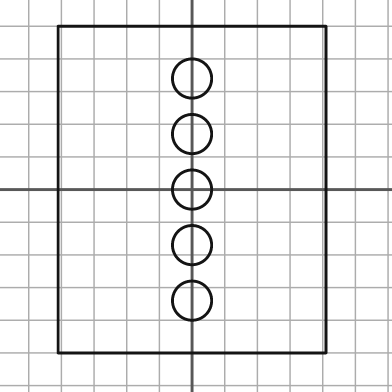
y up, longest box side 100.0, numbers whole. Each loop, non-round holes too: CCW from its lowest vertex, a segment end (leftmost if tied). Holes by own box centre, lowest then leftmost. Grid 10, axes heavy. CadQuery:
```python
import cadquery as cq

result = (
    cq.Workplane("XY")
    .moveTo(-41.0, -50.0)
    .lineTo(41.0, -50.0)
    .lineTo(41.0, 50.0)
    .lineTo(-41.0, 50.0)
    .close()
    .moveTo(0.0, -34.0)
    .circle(6.0)
    .moveTo(0.0, -17.0)
    .circle(6.0)
    .moveTo(0.0, 0.0)
    .circle(6.0)
    .moveTo(0.0, 17.0)
    .circle(6.0)
    .moveTo(0.0, 34.0)
    .circle(6.0)
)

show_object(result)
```